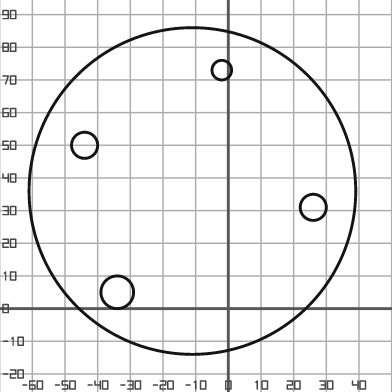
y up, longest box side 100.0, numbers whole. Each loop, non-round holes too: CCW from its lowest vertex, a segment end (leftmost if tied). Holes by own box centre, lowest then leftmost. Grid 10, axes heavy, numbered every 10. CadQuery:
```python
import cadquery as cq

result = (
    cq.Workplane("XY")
    .moveTo(-11.0, 36.0)
    .circle(50.0)
    .moveTo(-34.0, 5.0)
    .circle(5.0)
    .moveTo(26.0, 31.0)
    .circle(4.0)
    .moveTo(-44.0, 50.0)
    .circle(4.0)
    .moveTo(-2.0, 73.0)
    .circle(3.0)
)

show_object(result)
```